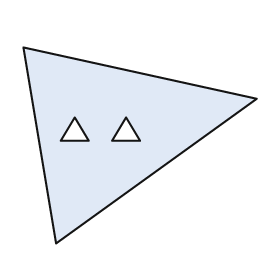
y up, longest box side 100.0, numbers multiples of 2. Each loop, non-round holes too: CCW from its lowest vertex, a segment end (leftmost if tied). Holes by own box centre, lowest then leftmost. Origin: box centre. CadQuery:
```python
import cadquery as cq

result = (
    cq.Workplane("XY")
    .moveTo(-36.0, -42.0)
    .lineTo(50.0, 20.0)
    .lineTo(-50.0, 42.0)
    .close()
    .moveTo(-34.0, 2.0)
    .lineTo(-22.0, 2.0)
    .lineTo(-28.0, 12.0)
    .close()
    .moveTo(-12.0, 2.0)
    .lineTo(0.0, 2.0)
    .lineTo(-6.0, 12.0)
    .close()
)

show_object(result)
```